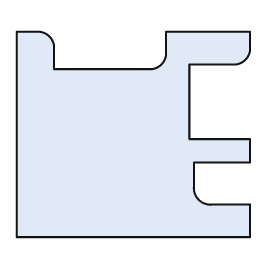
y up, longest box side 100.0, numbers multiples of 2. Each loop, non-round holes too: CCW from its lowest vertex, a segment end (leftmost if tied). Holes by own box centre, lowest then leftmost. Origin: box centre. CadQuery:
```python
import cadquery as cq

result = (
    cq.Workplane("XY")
    .moveTo(-50.0, -44.0)
    .lineTo(50.0, -44.0)
    .lineTo(50.0, -30.0)
    .lineTo(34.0, -30.0)
    .threePointArc((28.0, -28.0), (26.0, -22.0))
    .lineTo(26.0, -12.0)
    .lineTo(50.0, -12.0)
    .lineTo(50.0, -2.0)
    .lineTo(24.0, -2.0)
    .lineTo(24.0, 30.0)
    .lineTo(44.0, 30.0)
    .threePointArc((48.0, 32.0), (50.0, 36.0))
    .lineTo(50.0, 44.0)
    .lineTo(14.0, 44.0)
    .lineTo(14.0, 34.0)
    .threePointArc((12.0, 30.0), (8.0, 28.0))
    .lineTo(-34.0, 28.0)
    .lineTo(-34.0, 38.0)
    .threePointArc((-36.0, 42.0), (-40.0, 44.0))
    .lineTo(-50.0, 44.0)
    .close()
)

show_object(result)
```